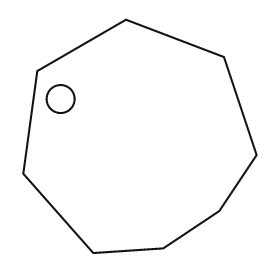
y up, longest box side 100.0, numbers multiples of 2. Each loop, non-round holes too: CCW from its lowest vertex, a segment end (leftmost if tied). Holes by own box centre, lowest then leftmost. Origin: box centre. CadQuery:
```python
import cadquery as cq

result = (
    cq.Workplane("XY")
    .moveTo(-20.0, -50.0)
    .lineTo(10.0, -48.0)
    .lineTo(34.0, -32.0)
    .lineTo(50.0, -8.0)
    .lineTo(36.0, 34.0)
    .lineTo(-6.0, 50.0)
    .lineTo(-44.0, 28.0)
    .lineTo(-50.0, -16.0)
    .close()
    .moveTo(-34.0, 16.0)
    .circle(6.0)
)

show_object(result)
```